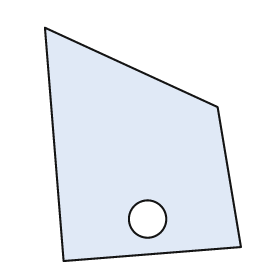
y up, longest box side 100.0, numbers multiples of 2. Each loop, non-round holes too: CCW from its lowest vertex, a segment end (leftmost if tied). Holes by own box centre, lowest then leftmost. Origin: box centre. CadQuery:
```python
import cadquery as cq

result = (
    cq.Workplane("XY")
    .moveTo(-34.0, -50.0)
    .lineTo(42.0, -44.0)
    .lineTo(32.0, 16.0)
    .lineTo(-42.0, 50.0)
    .close()
    .moveTo(2.0, -32.0)
    .circle(8.0)
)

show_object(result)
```